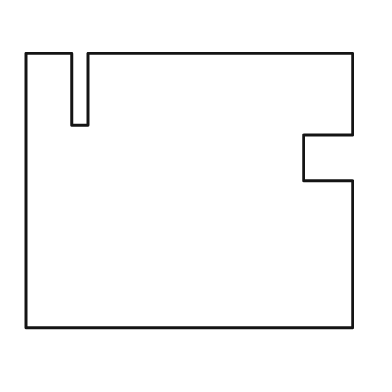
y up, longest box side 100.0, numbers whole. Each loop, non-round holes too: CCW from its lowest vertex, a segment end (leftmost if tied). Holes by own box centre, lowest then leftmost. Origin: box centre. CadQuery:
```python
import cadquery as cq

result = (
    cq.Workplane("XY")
    .moveTo(-50.0, -42.0)
    .lineTo(50.0, -42.0)
    .lineTo(50.0, 3.0)
    .lineTo(35.0, 3.0)
    .lineTo(35.0, 17.0)
    .lineTo(50.0, 17.0)
    .lineTo(50.0, 42.0)
    .lineTo(-31.0, 42.0)
    .lineTo(-31.0, 20.0)
    .lineTo(-36.0, 20.0)
    .lineTo(-36.0, 42.0)
    .lineTo(-50.0, 42.0)
    .close()
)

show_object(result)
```